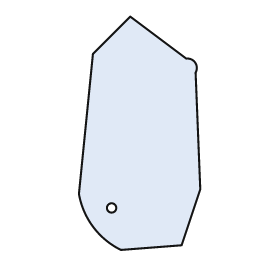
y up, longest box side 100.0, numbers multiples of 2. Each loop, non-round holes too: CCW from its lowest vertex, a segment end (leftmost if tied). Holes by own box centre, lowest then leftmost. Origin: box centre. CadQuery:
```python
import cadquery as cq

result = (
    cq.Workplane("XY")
    .moveTo(-8.0, -50.0)
    .lineTo(18.0, -48.0)
    .lineTo(26.0, -24.0)
    .lineTo(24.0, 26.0)
    .threePointArc((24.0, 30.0), (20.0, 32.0))
    .lineTo(-4.0, 50.0)
    .lineTo(-20.0, 34.0)
    .lineTo(-26.0, -26.0)
    .threePointArc((-20.0, -40.0), (-8.0, -50.0))
    .close()
    .moveTo(-12.0, -32.0)
    .circle(2.0)
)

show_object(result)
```